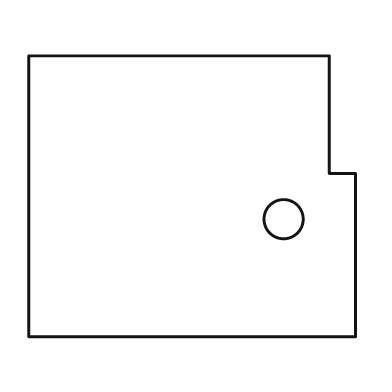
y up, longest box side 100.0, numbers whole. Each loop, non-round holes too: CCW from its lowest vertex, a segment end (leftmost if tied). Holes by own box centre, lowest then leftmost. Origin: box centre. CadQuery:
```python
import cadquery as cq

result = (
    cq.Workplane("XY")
    .moveTo(-50.0, -43.0)
    .lineTo(50.0, -43.0)
    .lineTo(50.0, 7.0)
    .lineTo(42.0, 7.0)
    .lineTo(42.0, 43.0)
    .lineTo(-50.0, 43.0)
    .close()
    .moveTo(28.0, -7.0)
    .circle(6.0)
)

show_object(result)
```